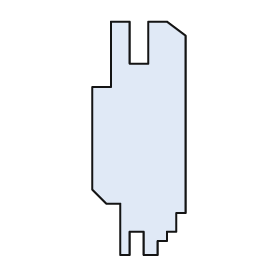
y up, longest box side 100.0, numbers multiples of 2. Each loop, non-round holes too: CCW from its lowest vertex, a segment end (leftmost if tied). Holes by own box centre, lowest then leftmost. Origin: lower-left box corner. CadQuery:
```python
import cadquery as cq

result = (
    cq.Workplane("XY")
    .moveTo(12.0, 0.0)
    .lineTo(16.0, 0.0)
    .lineTo(16.0, 10.0)
    .lineTo(22.0, 10.0)
    .lineTo(22.0, 0.0)
    .lineTo(28.0, 0.0)
    .lineTo(28.0, 6.0)
    .lineTo(32.0, 6.0)
    .lineTo(32.0, 10.0)
    .lineTo(36.0, 10.0)
    .lineTo(36.0, 18.0)
    .lineTo(40.0, 18.0)
    .lineTo(40.0, 94.0)
    .lineTo(32.0, 100.0)
    .lineTo(24.0, 100.0)
    .lineTo(24.0, 82.0)
    .lineTo(16.0, 82.0)
    .lineTo(16.0, 100.0)
    .lineTo(8.0, 100.0)
    .lineTo(8.0, 72.0)
    .lineTo(0.0, 72.0)
    .lineTo(0.0, 28.0)
    .lineTo(6.0, 22.0)
    .lineTo(12.0, 22.0)
    .close()
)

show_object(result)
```